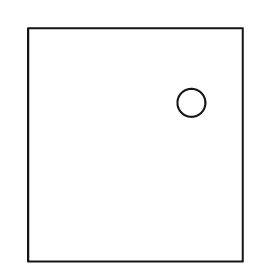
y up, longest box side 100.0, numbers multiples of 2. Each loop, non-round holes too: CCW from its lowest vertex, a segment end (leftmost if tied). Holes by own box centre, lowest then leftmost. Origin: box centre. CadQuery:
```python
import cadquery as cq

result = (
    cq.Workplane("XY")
    .moveTo(-46.0, -50.0)
    .lineTo(46.0, -50.0)
    .lineTo(46.0, 50.0)
    .lineTo(-46.0, 50.0)
    .close()
    .moveTo(24.0, 18.0)
    .circle(6.0)
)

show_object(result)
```